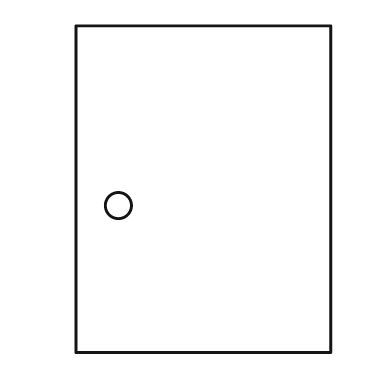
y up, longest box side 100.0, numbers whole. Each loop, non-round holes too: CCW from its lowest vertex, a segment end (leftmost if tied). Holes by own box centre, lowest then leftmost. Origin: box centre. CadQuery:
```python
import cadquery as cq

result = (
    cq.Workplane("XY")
    .moveTo(-39.0, -50.0)
    .lineTo(39.0, -50.0)
    .lineTo(39.0, 50.0)
    .lineTo(-39.0, 50.0)
    .close()
    .moveTo(-26.0, -5.0)
    .circle(4.0)
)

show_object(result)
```